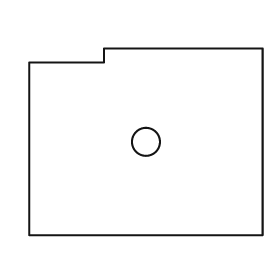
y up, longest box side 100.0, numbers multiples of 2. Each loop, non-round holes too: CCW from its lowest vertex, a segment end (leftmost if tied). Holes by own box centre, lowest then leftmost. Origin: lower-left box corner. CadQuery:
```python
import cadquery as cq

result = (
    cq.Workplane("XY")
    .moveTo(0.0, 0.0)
    .lineTo(100.0, 0.0)
    .lineTo(100.0, 80.0)
    .lineTo(32.0, 80.0)
    .lineTo(32.0, 74.0)
    .lineTo(0.0, 74.0)
    .close()
    .moveTo(50.0, 40.0)
    .circle(6.0)
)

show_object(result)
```